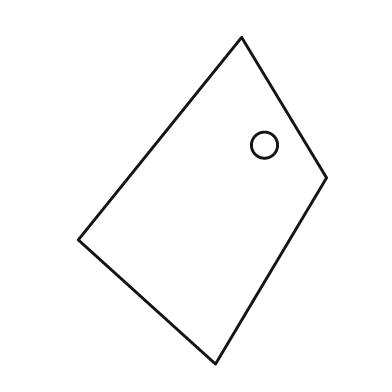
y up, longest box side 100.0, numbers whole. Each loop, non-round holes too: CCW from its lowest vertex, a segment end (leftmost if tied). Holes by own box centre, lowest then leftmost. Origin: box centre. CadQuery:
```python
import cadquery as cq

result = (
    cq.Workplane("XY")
    .moveTo(4.0, -50.0)
    .lineTo(38.0, 7.0)
    .lineTo(12.0, 50.0)
    .lineTo(-38.0, -12.0)
    .close()
    .moveTo(19.0, 17.0)
    .circle(4.0)
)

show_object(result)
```